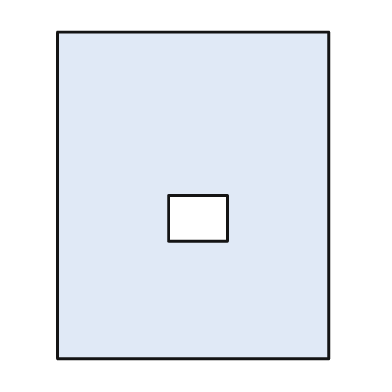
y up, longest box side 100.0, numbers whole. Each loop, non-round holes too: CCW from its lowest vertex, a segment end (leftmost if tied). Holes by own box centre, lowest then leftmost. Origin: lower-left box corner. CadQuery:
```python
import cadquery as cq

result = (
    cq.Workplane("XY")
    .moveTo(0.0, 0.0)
    .lineTo(83.0, 0.0)
    .lineTo(83.0, 100.0)
    .lineTo(0.0, 100.0)
    .close()
    .moveTo(34.0, 36.0)
    .lineTo(52.0, 36.0)
    .lineTo(52.0, 50.0)
    .lineTo(34.0, 50.0)
    .close()
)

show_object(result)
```